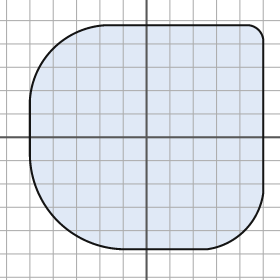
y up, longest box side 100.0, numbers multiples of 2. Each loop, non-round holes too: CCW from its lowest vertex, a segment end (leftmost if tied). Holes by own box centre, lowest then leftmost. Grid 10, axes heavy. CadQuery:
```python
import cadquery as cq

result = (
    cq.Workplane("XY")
    .moveTo(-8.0, -48.0)
    .lineTo(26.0, -48.0)
    .threePointArc((42.0, -40.0), (50.0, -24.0))
    .lineTo(50.0, 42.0)
    .threePointArc((48.0, 46.0), (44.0, 48.0))
    .lineTo(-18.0, 48.0)
    .threePointArc((-40.0, 38.0), (-50.0, 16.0))
    .lineTo(-50.0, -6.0)
    .threePointArc((-38.0, -36.0), (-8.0, -48.0))
    .close()
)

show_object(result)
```